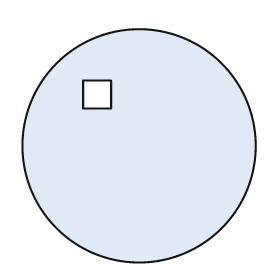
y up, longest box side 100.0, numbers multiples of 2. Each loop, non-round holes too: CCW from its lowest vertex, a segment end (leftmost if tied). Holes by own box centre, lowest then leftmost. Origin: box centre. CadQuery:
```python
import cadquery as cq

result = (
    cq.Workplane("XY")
    .moveTo(0.0, 0.0)
    .circle(50.0)
    .moveTo(-24.0, 16.0)
    .lineTo(-12.0, 16.0)
    .lineTo(-12.0, 28.0)
    .lineTo(-24.0, 28.0)
    .close()
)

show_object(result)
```